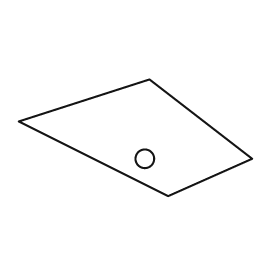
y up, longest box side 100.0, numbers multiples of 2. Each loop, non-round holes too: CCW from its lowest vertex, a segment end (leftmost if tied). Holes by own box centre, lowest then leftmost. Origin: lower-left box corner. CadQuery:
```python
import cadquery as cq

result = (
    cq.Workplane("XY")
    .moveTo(64.0, 0.0)
    .lineTo(100.0, 16.0)
    .lineTo(56.0, 50.0)
    .lineTo(0.0, 32.0)
    .close()
    .moveTo(54.0, 16.0)
    .circle(4.0)
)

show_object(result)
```